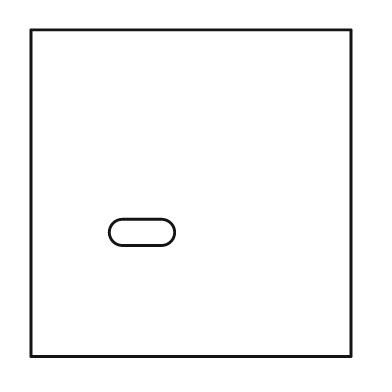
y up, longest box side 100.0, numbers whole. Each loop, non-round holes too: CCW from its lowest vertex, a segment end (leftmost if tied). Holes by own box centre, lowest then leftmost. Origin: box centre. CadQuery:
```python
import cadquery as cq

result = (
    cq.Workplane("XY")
    .moveTo(-49.0, -50.0)
    .lineTo(49.0, -50.0)
    .lineTo(49.0, 50.0)
    .lineTo(-49.0, 50.0)
    .close()
    .moveTo(-21.0, -16.0)
    .lineTo(-9.0, -16.0)
    .threePointArc((-5.0, -12.0), (-9.0, -8.0))
    .lineTo(-21.0, -8.0)
    .threePointArc((-25.0, -12.0), (-21.0, -16.0))
    .close()
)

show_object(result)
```